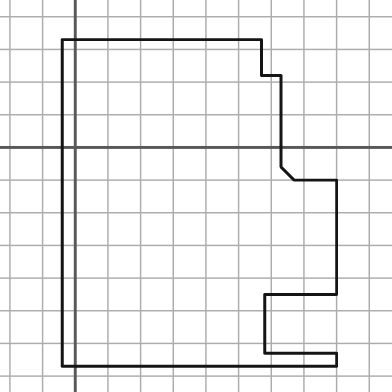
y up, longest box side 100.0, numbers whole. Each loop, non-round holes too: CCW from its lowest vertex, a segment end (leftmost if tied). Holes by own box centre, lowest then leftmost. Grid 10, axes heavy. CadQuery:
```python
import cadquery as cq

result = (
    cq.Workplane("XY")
    .moveTo(-4.0, -67.0)
    .lineTo(80.0, -67.0)
    .lineTo(80.0, -63.0)
    .lineTo(58.0, -63.0)
    .lineTo(58.0, -45.0)
    .lineTo(80.0, -45.0)
    .lineTo(80.0, -10.0)
    .lineTo(67.0, -10.0)
    .lineTo(63.0, -6.0)
    .lineTo(63.0, 22.0)
    .lineTo(57.0, 22.0)
    .lineTo(57.0, 33.0)
    .lineTo(-4.0, 33.0)
    .close()
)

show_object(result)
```